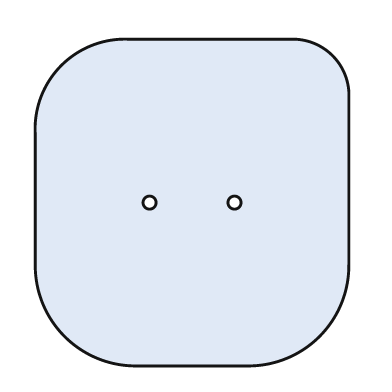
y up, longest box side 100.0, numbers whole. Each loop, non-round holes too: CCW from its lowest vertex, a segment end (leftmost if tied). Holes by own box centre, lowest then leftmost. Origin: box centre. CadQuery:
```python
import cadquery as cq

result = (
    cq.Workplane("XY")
    .moveTo(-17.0, -50.0)
    .lineTo(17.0, -50.0)
    .threePointArc((39.0, -41.0), (48.0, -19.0))
    .lineTo(48.0, 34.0)
    .threePointArc((43.0, 45.0), (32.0, 50.0))
    .lineTo(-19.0, 50.0)
    .threePointArc((-40.0, 42.0), (-48.0, 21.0))
    .lineTo(-48.0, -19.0)
    .threePointArc((-39.0, -41.0), (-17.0, -50.0))
    .close()
    .moveTo(-13.0, 0.0)
    .circle(2.0)
    .moveTo(13.0, 0.0)
    .circle(2.0)
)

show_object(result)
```